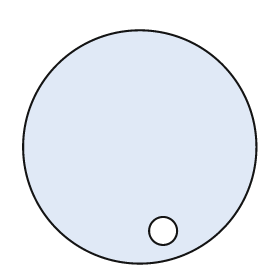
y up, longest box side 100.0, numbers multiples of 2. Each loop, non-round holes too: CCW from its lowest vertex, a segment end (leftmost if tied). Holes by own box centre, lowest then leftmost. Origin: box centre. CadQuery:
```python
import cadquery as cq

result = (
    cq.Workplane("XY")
    .moveTo(0.0, 0.0)
    .circle(50.0)
    .moveTo(10.0, -36.0)
    .circle(6.0)
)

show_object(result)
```